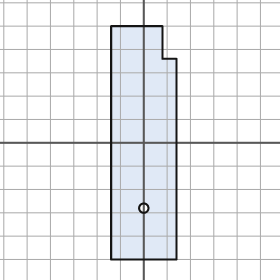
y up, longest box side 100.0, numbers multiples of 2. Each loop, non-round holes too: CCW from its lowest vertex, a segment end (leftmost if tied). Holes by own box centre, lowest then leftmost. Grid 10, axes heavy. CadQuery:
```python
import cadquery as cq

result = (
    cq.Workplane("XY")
    .moveTo(-14.0, -50.0)
    .lineTo(14.0, -50.0)
    .lineTo(14.0, 36.0)
    .lineTo(8.0, 36.0)
    .lineTo(8.0, 50.0)
    .lineTo(-14.0, 50.0)
    .close()
    .moveTo(0.0, -28.0)
    .circle(2.0)
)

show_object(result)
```